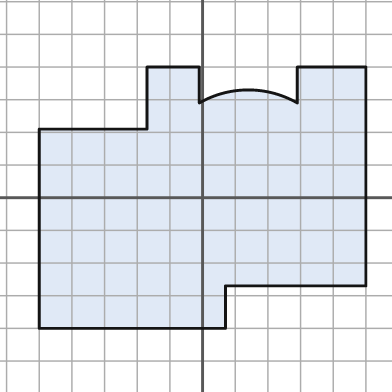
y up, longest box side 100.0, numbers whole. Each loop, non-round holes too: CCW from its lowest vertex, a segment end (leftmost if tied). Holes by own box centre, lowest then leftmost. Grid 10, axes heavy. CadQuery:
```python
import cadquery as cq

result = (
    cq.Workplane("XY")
    .moveTo(-50.0, -40.0)
    .lineTo(7.0, -40.0)
    .lineTo(7.0, -27.0)
    .lineTo(50.0, -27.0)
    .lineTo(50.0, 40.0)
    .lineTo(29.0, 40.0)
    .lineTo(29.0, 29.0)
    .threePointArc((14.0, 33.0), (-1.0, 29.0))
    .lineTo(-1.0, 40.0)
    .lineTo(-17.0, 40.0)
    .lineTo(-17.0, 21.0)
    .lineTo(-50.0, 21.0)
    .close()
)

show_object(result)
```